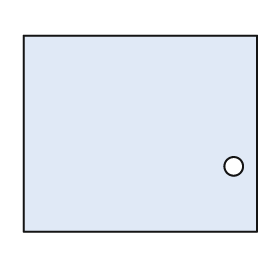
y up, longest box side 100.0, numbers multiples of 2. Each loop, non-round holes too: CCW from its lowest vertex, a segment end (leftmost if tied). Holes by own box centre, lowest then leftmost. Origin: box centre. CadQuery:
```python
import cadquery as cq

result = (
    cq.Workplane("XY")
    .moveTo(-50.0, -42.0)
    .lineTo(50.0, -42.0)
    .lineTo(50.0, 42.0)
    .lineTo(-50.0, 42.0)
    .close()
    .moveTo(40.0, -14.0)
    .circle(4.0)
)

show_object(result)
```